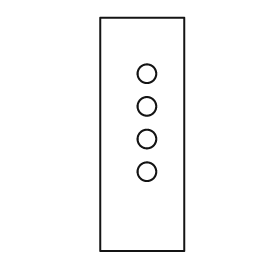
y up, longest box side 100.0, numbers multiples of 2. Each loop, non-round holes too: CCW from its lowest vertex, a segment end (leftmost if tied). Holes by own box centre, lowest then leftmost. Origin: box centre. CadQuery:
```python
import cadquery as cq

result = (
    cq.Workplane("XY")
    .moveTo(-18.0, -50.0)
    .lineTo(18.0, -50.0)
    .lineTo(18.0, 50.0)
    .lineTo(-18.0, 50.0)
    .close()
    .moveTo(2.0, -16.0)
    .circle(4.0)
    .moveTo(2.0, -2.0)
    .circle(4.0)
    .moveTo(2.0, 12.0)
    .circle(4.0)
    .moveTo(2.0, 26.0)
    .circle(4.0)
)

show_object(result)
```